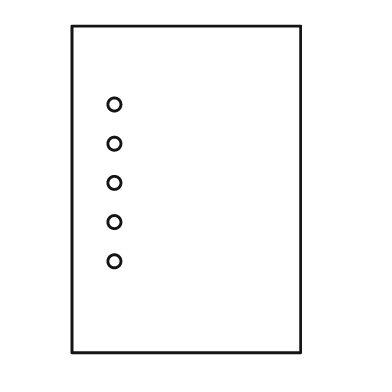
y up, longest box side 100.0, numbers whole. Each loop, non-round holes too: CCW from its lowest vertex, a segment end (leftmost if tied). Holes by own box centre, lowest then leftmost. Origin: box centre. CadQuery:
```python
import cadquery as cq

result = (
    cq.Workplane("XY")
    .moveTo(-35.0, -50.0)
    .lineTo(35.0, -50.0)
    .lineTo(35.0, 50.0)
    .lineTo(-35.0, 50.0)
    .close()
    .moveTo(-22.0, -22.0)
    .circle(2.0)
    .moveTo(-22.0, -10.0)
    .circle(2.0)
    .moveTo(-22.0, 2.0)
    .circle(2.0)
    .moveTo(-22.0, 14.0)
    .circle(2.0)
    .moveTo(-22.0, 26.0)
    .circle(2.0)
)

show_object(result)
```